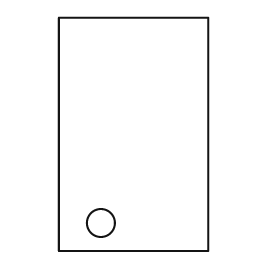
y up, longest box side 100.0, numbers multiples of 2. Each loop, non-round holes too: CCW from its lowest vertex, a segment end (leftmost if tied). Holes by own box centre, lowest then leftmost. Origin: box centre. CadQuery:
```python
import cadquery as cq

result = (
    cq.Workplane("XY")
    .moveTo(-32.0, -50.0)
    .lineTo(32.0, -50.0)
    .lineTo(32.0, 50.0)
    .lineTo(-32.0, 50.0)
    .close()
    .moveTo(-14.0, -38.0)
    .circle(6.0)
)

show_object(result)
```